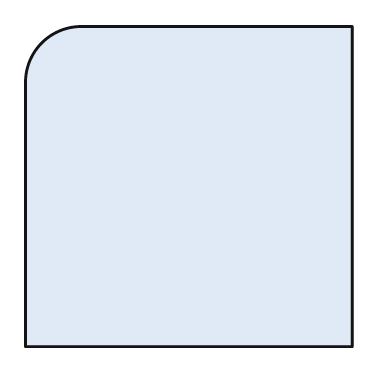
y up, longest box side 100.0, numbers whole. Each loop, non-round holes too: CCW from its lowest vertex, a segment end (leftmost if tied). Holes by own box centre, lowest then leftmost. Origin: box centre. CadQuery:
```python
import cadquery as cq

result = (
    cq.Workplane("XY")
    .moveTo(-50.0, -49.0)
    .lineTo(50.0, -49.0)
    .lineTo(50.0, 49.0)
    .lineTo(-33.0, 49.0)
    .threePointArc((-45.0, 44.0), (-50.0, 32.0))
    .close()
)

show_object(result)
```